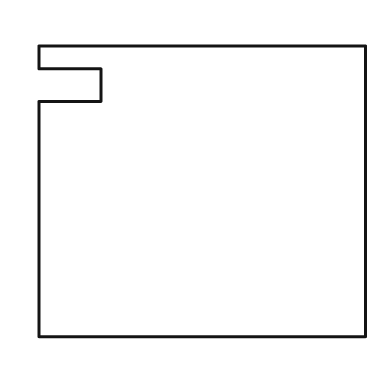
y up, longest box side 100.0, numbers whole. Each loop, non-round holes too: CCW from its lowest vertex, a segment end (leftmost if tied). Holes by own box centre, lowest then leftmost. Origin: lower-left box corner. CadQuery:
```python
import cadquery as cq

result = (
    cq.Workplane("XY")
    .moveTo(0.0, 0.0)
    .lineTo(100.0, 0.0)
    .lineTo(100.0, 89.0)
    .lineTo(0.0, 89.0)
    .lineTo(0.0, 82.0)
    .lineTo(19.0, 82.0)
    .lineTo(19.0, 72.0)
    .lineTo(0.0, 72.0)
    .close()
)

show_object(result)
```